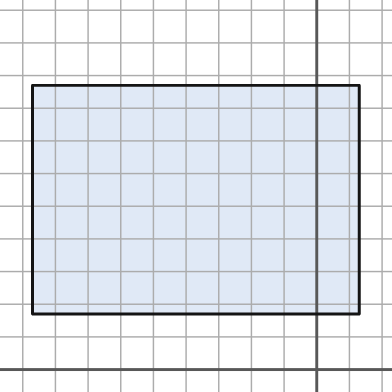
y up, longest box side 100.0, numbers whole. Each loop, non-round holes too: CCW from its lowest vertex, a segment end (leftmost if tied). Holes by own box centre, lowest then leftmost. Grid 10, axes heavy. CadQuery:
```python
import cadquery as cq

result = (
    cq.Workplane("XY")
    .moveTo(-87.0, 17.0)
    .lineTo(13.0, 17.0)
    .lineTo(13.0, 87.0)
    .lineTo(-87.0, 87.0)
    .close()
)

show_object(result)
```